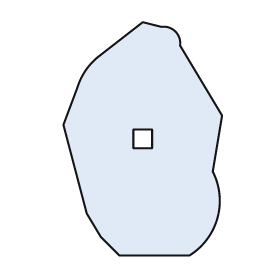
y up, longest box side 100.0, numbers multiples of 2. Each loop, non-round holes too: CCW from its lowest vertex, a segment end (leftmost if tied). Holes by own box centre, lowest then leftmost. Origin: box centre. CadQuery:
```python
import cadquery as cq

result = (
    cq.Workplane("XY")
    .moveTo(-10.0, -50.0)
    .lineTo(20.0, -50.0)
    .threePointArc((32.0, -34.0), (30.0, -14.0))
    .lineTo(34.0, 10.0)
    .lineTo(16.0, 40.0)
    .threePointArc((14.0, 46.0), (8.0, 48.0))
    .lineTo(0.0, 50.0)
    .lineTo(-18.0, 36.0)
    .threePointArc((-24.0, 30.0), (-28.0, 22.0))
    .lineTo(-34.0, 6.0)
    .lineTo(-24.0, -32.0)
    .lineTo(-18.0, -42.0)
    .close()
    .moveTo(-4.0, -4.0)
    .lineTo(4.0, -4.0)
    .lineTo(4.0, 4.0)
    .lineTo(-4.0, 4.0)
    .close()
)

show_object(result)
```